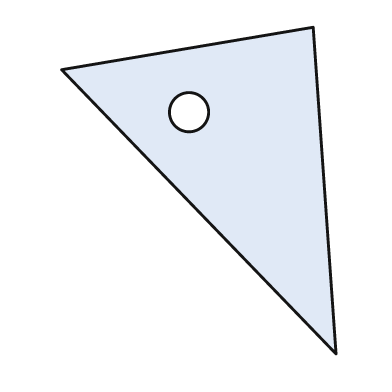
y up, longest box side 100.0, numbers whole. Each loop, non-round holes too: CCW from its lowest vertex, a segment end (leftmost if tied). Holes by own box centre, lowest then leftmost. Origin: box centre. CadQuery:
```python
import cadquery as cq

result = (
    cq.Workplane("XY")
    .moveTo(42.0, -50.0)
    .lineTo(35.0, 50.0)
    .lineTo(-42.0, 37.0)
    .close()
    .moveTo(-3.0, 24.0)
    .circle(6.0)
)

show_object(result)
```